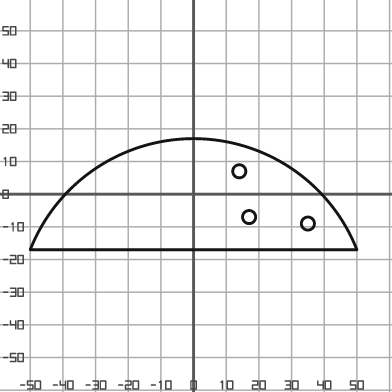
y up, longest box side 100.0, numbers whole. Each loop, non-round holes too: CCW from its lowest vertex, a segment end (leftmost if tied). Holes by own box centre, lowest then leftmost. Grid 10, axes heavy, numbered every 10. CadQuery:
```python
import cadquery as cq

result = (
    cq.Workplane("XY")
    .moveTo(-50.0, -17.0)
    .lineTo(50.0, -17.0)
    .threePointArc((0.0, 17.0), (-50.0, -17.0))
    .close()
    .moveTo(35.0, -9.0)
    .circle(2.0)
    .moveTo(17.0, -7.0)
    .circle(2.0)
    .moveTo(14.0, 7.0)
    .circle(2.0)
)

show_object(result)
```